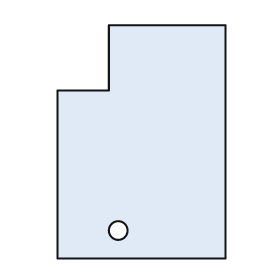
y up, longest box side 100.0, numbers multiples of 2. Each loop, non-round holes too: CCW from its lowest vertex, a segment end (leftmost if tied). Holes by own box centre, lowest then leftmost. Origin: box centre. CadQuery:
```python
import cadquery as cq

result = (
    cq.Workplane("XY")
    .moveTo(-36.0, -50.0)
    .lineTo(36.0, -50.0)
    .lineTo(36.0, 50.0)
    .lineTo(-14.0, 50.0)
    .lineTo(-14.0, 22.0)
    .lineTo(-36.0, 22.0)
    .close()
    .moveTo(-10.0, -38.0)
    .circle(4.0)
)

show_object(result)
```